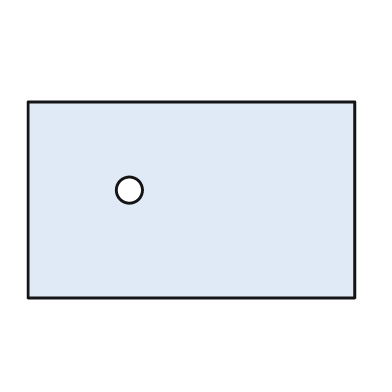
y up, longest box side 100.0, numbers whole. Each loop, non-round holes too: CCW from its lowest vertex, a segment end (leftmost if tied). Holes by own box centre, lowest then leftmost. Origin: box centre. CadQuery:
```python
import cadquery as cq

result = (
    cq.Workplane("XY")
    .moveTo(-50.0, -30.0)
    .lineTo(50.0, -30.0)
    .lineTo(50.0, 30.0)
    .lineTo(-50.0, 30.0)
    .close()
    .moveTo(-19.0, 3.0)
    .circle(4.0)
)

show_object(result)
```